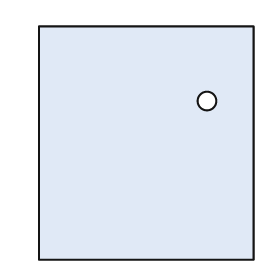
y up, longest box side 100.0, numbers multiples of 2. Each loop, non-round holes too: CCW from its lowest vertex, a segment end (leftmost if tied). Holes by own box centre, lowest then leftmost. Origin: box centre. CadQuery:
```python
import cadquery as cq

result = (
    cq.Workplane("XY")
    .moveTo(-46.0, -50.0)
    .lineTo(46.0, -50.0)
    .lineTo(46.0, 50.0)
    .lineTo(-46.0, 50.0)
    .close()
    .moveTo(26.0, 18.0)
    .circle(4.0)
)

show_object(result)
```